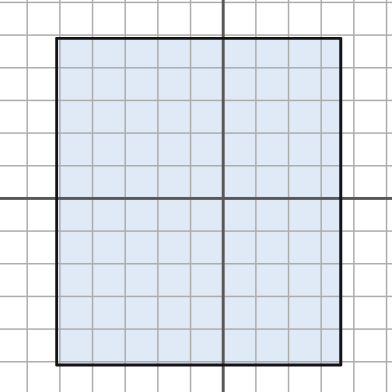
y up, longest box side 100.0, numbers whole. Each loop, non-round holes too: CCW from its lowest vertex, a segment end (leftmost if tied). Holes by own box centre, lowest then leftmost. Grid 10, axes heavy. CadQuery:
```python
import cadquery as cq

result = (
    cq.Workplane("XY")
    .moveTo(-51.0, -51.0)
    .lineTo(36.0, -51.0)
    .lineTo(36.0, 49.0)
    .lineTo(-51.0, 49.0)
    .close()
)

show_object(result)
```